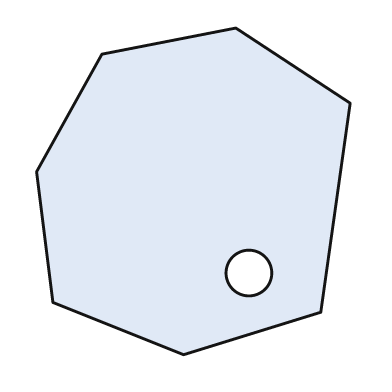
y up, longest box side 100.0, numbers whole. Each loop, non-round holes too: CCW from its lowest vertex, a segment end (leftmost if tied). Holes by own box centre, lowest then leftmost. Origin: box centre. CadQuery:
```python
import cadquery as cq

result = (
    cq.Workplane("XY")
    .moveTo(-3.0, -50.0)
    .lineTo(39.0, -37.0)
    .lineTo(48.0, 27.0)
    .lineTo(13.0, 50.0)
    .lineTo(-28.0, 42.0)
    .lineTo(-48.0, 6.0)
    .lineTo(-43.0, -34.0)
    .close()
    .moveTo(17.0, -25.0)
    .circle(7.0)
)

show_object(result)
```